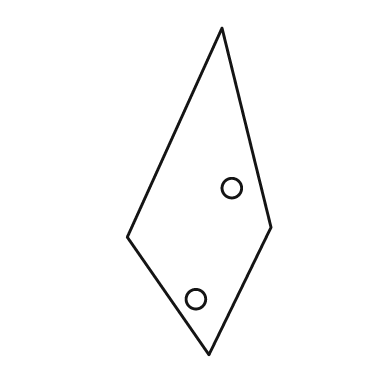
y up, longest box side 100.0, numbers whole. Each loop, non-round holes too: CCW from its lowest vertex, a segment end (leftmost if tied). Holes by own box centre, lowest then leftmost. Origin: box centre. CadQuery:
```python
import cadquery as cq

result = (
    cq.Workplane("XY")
    .moveTo(3.0, -50.0)
    .lineTo(22.0, -11.0)
    .lineTo(7.0, 50.0)
    .lineTo(-22.0, -14.0)
    .close()
    .moveTo(-1.0, -33.0)
    .circle(3.0)
    .moveTo(10.0, 1.0)
    .circle(3.0)
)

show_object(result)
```